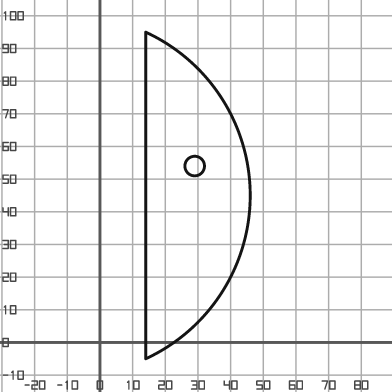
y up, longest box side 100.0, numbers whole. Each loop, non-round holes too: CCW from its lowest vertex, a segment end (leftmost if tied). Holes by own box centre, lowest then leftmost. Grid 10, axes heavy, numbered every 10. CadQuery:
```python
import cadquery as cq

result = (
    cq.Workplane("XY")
    .moveTo(14.0, -5.0)
    .threePointArc((46.0, 45.0), (14.0, 95.0))
    .close()
    .moveTo(29.0, 54.0)
    .circle(3.0)
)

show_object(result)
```